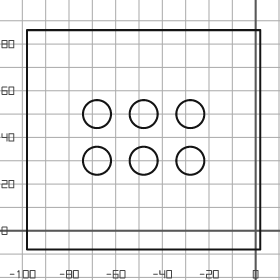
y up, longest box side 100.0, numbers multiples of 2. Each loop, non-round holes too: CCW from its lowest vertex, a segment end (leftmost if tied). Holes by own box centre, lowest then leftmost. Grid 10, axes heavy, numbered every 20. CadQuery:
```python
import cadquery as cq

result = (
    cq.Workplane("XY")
    .moveTo(-98.0, -8.0)
    .lineTo(2.0, -8.0)
    .lineTo(2.0, 86.0)
    .lineTo(-98.0, 86.0)
    .close()
    .moveTo(-68.0, 30.0)
    .circle(6.0)
    .moveTo(-48.0, 30.0)
    .circle(6.0)
    .moveTo(-28.0, 30.0)
    .circle(6.0)
    .moveTo(-68.0, 50.0)
    .circle(6.0)
    .moveTo(-48.0, 50.0)
    .circle(6.0)
    .moveTo(-28.0, 50.0)
    .circle(6.0)
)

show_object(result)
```